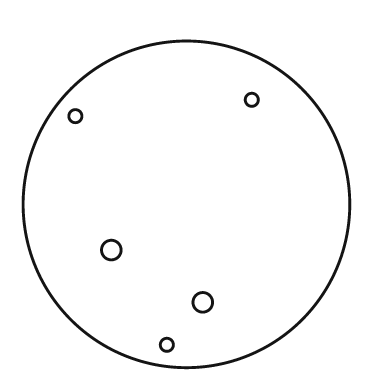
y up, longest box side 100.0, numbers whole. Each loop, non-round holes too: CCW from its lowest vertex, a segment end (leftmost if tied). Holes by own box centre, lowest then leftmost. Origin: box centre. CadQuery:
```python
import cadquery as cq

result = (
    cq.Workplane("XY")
    .moveTo(0.0, 0.0)
    .circle(50.0)
    .moveTo(-6.0, -43.0)
    .circle(2.0)
    .moveTo(5.0, -30.0)
    .circle(3.0)
    .moveTo(-23.0, -14.0)
    .circle(3.0)
    .moveTo(-34.0, 27.0)
    .circle(2.0)
    .moveTo(20.0, 32.0)
    .circle(2.0)
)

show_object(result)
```